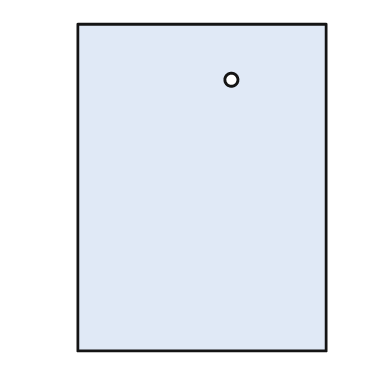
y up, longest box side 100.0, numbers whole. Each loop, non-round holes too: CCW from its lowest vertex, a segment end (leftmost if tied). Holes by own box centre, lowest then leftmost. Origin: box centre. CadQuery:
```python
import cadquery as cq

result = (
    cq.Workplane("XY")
    .moveTo(-38.0, -50.0)
    .lineTo(38.0, -50.0)
    .lineTo(38.0, 50.0)
    .lineTo(-38.0, 50.0)
    .close()
    .moveTo(9.0, 33.0)
    .circle(2.0)
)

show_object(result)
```